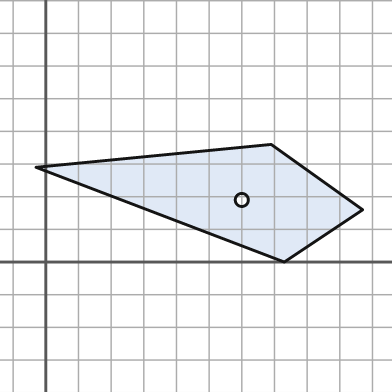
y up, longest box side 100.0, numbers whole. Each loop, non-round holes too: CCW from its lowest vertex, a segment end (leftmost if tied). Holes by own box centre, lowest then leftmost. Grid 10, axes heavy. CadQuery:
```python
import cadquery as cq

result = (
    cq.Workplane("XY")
    .moveTo(73.0, 0.0)
    .lineTo(97.0, 16.0)
    .lineTo(69.0, 36.0)
    .lineTo(-3.0, 29.0)
    .close()
    .moveTo(60.0, 19.0)
    .circle(2.0)
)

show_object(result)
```